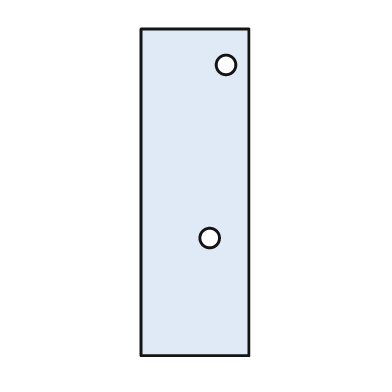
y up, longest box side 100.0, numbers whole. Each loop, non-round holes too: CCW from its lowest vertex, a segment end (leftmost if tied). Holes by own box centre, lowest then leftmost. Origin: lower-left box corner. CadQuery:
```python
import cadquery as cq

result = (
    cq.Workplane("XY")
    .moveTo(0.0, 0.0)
    .lineTo(33.0, 0.0)
    .lineTo(33.0, 100.0)
    .lineTo(0.0, 100.0)
    .close()
    .moveTo(21.0, 36.0)
    .circle(3.0)
    .moveTo(26.0, 89.0)
    .circle(3.0)
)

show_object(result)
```